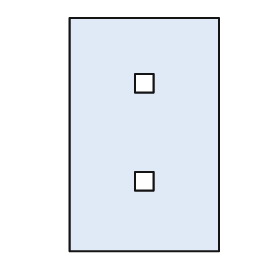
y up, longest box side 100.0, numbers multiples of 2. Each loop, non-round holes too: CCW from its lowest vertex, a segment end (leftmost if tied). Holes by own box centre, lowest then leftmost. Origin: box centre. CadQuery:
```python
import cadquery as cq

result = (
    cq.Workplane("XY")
    .moveTo(-32.0, -50.0)
    .lineTo(32.0, -50.0)
    .lineTo(32.0, 50.0)
    .lineTo(-32.0, 50.0)
    .close()
    .moveTo(-4.0, -24.0)
    .lineTo(4.0, -24.0)
    .lineTo(4.0, -16.0)
    .lineTo(-4.0, -16.0)
    .close()
    .moveTo(-4.0, 18.0)
    .lineTo(4.0, 18.0)
    .lineTo(4.0, 26.0)
    .lineTo(-4.0, 26.0)
    .close()
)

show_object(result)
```